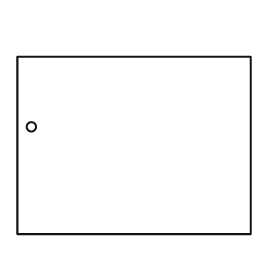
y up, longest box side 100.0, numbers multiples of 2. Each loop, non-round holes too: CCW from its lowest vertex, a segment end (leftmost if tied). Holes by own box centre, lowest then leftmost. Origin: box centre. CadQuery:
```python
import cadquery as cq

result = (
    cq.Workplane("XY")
    .moveTo(-50.0, -38.0)
    .lineTo(50.0, -38.0)
    .lineTo(50.0, 38.0)
    .lineTo(-50.0, 38.0)
    .close()
    .moveTo(-44.0, 8.0)
    .circle(2.0)
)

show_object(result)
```